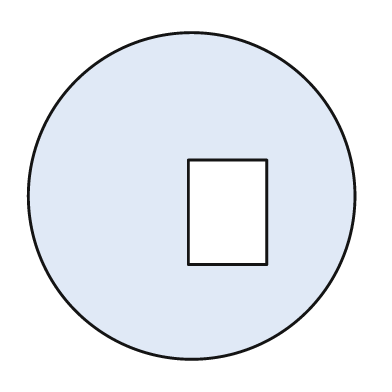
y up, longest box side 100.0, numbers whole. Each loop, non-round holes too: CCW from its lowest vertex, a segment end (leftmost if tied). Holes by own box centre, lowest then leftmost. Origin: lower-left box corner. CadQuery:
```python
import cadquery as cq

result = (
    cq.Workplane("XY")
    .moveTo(50.0, 50.0)
    .circle(50.0)
    .moveTo(49.0, 29.0)
    .lineTo(73.0, 29.0)
    .lineTo(73.0, 61.0)
    .lineTo(49.0, 61.0)
    .close()
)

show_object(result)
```